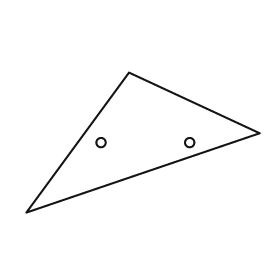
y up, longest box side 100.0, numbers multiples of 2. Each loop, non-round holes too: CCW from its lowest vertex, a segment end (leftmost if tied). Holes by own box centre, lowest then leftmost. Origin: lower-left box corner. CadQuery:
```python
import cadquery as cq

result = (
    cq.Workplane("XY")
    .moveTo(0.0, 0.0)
    .lineTo(100.0, 34.0)
    .lineTo(44.0, 60.0)
    .close()
    .moveTo(32.0, 30.0)
    .circle(2.0)
    .moveTo(70.0, 30.0)
    .circle(2.0)
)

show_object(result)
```